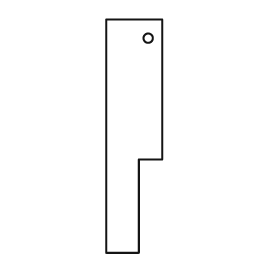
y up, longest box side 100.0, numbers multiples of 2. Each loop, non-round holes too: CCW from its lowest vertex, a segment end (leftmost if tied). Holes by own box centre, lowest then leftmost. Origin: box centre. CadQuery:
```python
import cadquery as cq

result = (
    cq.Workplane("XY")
    .moveTo(-12.0, -50.0)
    .lineTo(2.0, -50.0)
    .lineTo(2.0, -10.0)
    .lineTo(12.0, -10.0)
    .lineTo(12.0, 50.0)
    .lineTo(-12.0, 50.0)
    .close()
    .moveTo(6.0, 42.0)
    .circle(2.0)
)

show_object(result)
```